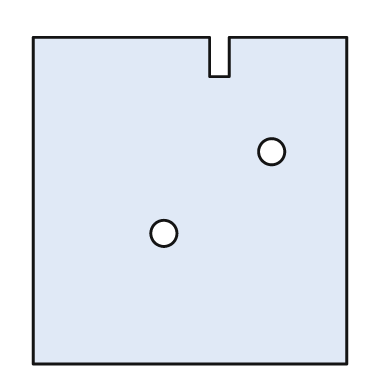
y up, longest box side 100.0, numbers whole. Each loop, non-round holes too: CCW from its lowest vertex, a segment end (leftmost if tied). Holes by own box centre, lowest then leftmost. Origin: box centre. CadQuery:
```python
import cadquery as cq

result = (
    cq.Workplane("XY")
    .moveTo(-48.0, -50.0)
    .lineTo(48.0, -50.0)
    .lineTo(48.0, 50.0)
    .lineTo(12.0, 50.0)
    .lineTo(12.0, 38.0)
    .lineTo(6.0, 38.0)
    .lineTo(6.0, 50.0)
    .lineTo(-48.0, 50.0)
    .close()
    .moveTo(-8.0, -10.0)
    .circle(4.0)
    .moveTo(25.0, 15.0)
    .circle(4.0)
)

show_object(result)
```